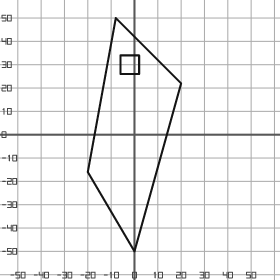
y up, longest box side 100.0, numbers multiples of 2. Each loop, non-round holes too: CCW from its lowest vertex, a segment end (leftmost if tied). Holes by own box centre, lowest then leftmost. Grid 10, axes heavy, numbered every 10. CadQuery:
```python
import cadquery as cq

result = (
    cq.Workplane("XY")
    .moveTo(0.0, -50.0)
    .lineTo(20.0, 22.0)
    .lineTo(-8.0, 50.0)
    .lineTo(-20.0, -16.0)
    .close()
    .moveTo(-6.0, 26.0)
    .lineTo(2.0, 26.0)
    .lineTo(2.0, 34.0)
    .lineTo(-6.0, 34.0)
    .close()
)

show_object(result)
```